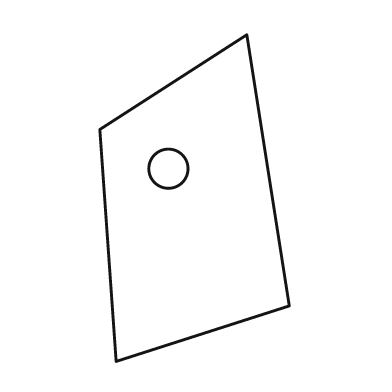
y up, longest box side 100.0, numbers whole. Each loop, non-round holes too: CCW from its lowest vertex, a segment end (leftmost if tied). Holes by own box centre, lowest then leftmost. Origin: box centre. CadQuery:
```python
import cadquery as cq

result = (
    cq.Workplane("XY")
    .moveTo(-24.0, -50.0)
    .lineTo(29.0, -33.0)
    .lineTo(16.0, 50.0)
    .lineTo(-29.0, 21.0)
    .close()
    .moveTo(-8.0, 9.0)
    .circle(6.0)
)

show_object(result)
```